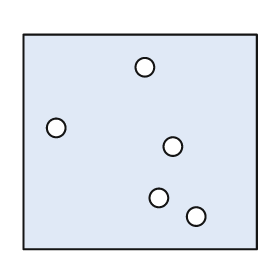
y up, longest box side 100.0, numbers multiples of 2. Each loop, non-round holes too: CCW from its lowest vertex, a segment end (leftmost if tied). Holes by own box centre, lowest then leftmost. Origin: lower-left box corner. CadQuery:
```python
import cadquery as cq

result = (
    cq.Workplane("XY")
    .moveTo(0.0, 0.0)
    .lineTo(100.0, 0.0)
    .lineTo(100.0, 92.0)
    .lineTo(0.0, 92.0)
    .close()
    .moveTo(74.0, 14.0)
    .circle(4.0)
    .moveTo(58.0, 22.0)
    .circle(4.0)
    .moveTo(64.0, 44.0)
    .circle(4.0)
    .moveTo(14.0, 52.0)
    .circle(4.0)
    .moveTo(52.0, 78.0)
    .circle(4.0)
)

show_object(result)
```